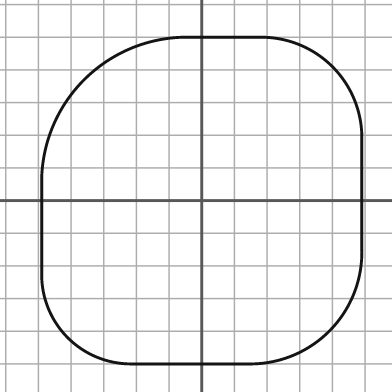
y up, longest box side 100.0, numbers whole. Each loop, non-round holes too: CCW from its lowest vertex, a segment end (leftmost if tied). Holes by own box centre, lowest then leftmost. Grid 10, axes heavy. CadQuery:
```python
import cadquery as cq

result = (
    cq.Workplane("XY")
    .moveTo(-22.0, -50.0)
    .lineTo(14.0, -50.0)
    .threePointArc((39.0, -40.0), (49.0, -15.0))
    .lineTo(49.0, 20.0)
    .threePointArc((40.0, 41.0), (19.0, 50.0))
    .lineTo(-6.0, 50.0)
    .threePointArc((-36.0, 37.0), (-49.0, 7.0))
    .lineTo(-49.0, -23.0)
    .threePointArc((-41.0, -42.0), (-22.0, -50.0))
    .close()
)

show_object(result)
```